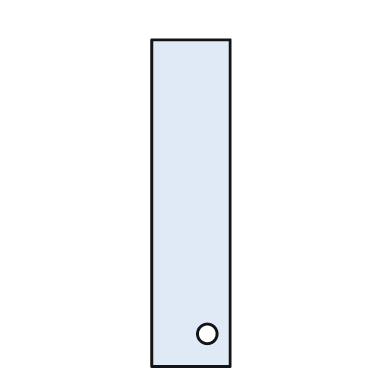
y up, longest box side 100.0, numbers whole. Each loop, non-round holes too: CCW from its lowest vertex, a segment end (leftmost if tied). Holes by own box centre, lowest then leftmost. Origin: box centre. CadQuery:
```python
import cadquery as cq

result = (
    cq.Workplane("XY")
    .moveTo(-12.0, -50.0)
    .lineTo(12.0, -50.0)
    .lineTo(12.0, 50.0)
    .lineTo(-12.0, 50.0)
    .close()
    .moveTo(5.0, -40.0)
    .circle(3.0)
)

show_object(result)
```